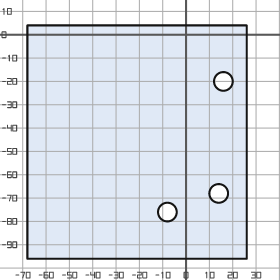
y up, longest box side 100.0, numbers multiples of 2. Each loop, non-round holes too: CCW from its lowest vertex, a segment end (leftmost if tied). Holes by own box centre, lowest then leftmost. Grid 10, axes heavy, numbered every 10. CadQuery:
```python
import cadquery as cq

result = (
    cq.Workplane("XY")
    .moveTo(-68.0, -96.0)
    .lineTo(26.0, -96.0)
    .lineTo(26.0, 4.0)
    .lineTo(-68.0, 4.0)
    .close()
    .moveTo(-8.0, -76.0)
    .circle(4.0)
    .moveTo(14.0, -68.0)
    .circle(4.0)
    .moveTo(16.0, -20.0)
    .circle(4.0)
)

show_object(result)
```